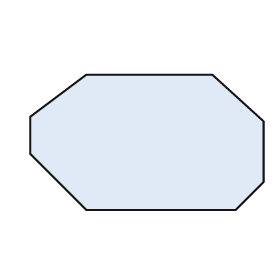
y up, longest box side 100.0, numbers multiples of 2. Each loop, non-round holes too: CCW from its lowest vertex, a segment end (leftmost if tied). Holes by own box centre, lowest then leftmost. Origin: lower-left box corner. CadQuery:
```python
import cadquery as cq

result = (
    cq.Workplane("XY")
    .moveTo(24.0, 0.0)
    .lineTo(88.0, 0.0)
    .lineTo(100.0, 12.0)
    .lineTo(100.0, 38.0)
    .lineTo(78.0, 58.0)
    .lineTo(24.0, 58.0)
    .lineTo(0.0, 40.0)
    .lineTo(0.0, 24.0)
    .close()
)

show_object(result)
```